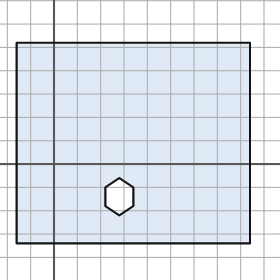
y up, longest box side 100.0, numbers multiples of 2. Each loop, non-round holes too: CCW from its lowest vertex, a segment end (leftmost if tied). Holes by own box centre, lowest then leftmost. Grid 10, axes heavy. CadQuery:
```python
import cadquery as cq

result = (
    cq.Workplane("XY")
    .moveTo(-16.0, -34.0)
    .lineTo(84.0, -34.0)
    .lineTo(84.0, 52.0)
    .lineTo(-16.0, 52.0)
    .close()
    .moveTo(28.0, -22.0)
    .lineTo(34.0, -18.0)
    .lineTo(34.0, -10.0)
    .lineTo(28.0, -6.0)
    .lineTo(22.0, -10.0)
    .lineTo(22.0, -18.0)
    .close()
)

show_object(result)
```